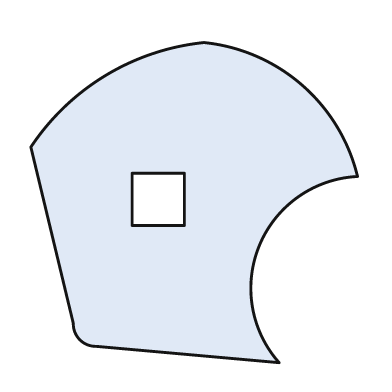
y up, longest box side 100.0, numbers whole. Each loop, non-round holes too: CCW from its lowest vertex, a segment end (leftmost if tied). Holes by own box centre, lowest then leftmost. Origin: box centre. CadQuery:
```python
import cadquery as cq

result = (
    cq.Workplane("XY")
    .moveTo(26.0, -49.0)
    .threePointArc((20.0, -13.0), (50.0, 8.0))
    .threePointArc((33.0, 36.0), (3.0, 49.0))
    .threePointArc((-27.0, 39.0), (-50.0, 17.0))
    .lineTo(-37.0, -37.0)
    .threePointArc((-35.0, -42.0), (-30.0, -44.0))
    .close()
    .moveTo(-19.0, -7.0)
    .lineTo(-3.0, -7.0)
    .lineTo(-3.0, 9.0)
    .lineTo(-19.0, 9.0)
    .close()
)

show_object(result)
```